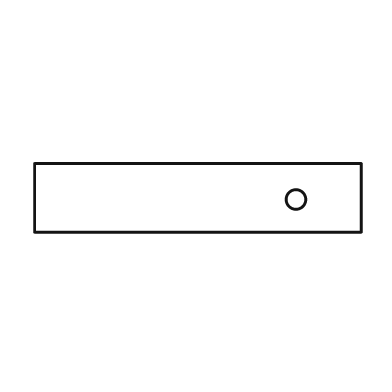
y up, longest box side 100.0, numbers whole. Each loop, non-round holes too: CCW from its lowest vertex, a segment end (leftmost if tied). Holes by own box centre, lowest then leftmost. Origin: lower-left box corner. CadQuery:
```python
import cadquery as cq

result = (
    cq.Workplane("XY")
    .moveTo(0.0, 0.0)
    .lineTo(100.0, 0.0)
    .lineTo(100.0, 21.0)
    .lineTo(0.0, 21.0)
    .close()
    .moveTo(80.0, 10.0)
    .circle(3.0)
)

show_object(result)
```